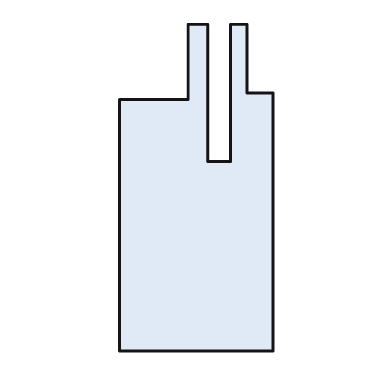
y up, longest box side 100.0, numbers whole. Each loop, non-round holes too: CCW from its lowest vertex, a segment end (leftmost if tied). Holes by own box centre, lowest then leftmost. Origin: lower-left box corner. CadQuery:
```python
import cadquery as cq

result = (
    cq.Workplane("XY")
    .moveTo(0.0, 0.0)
    .lineTo(47.0, 0.0)
    .lineTo(47.0, 79.0)
    .lineTo(39.0, 79.0)
    .lineTo(39.0, 100.0)
    .lineTo(34.0, 100.0)
    .lineTo(34.0, 58.0)
    .lineTo(27.0, 58.0)
    .lineTo(27.0, 100.0)
    .lineTo(21.0, 100.0)
    .lineTo(21.0, 77.0)
    .lineTo(0.0, 77.0)
    .close()
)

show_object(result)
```